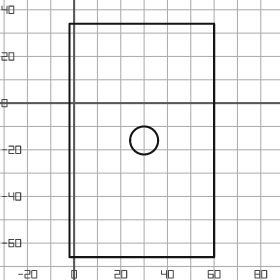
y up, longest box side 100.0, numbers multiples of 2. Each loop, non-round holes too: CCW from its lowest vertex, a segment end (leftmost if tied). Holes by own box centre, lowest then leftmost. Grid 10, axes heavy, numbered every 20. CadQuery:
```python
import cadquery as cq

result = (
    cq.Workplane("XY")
    .moveTo(-2.0, -66.0)
    .lineTo(60.0, -66.0)
    .lineTo(60.0, 34.0)
    .lineTo(-2.0, 34.0)
    .close()
    .moveTo(30.0, -16.0)
    .circle(6.0)
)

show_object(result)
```